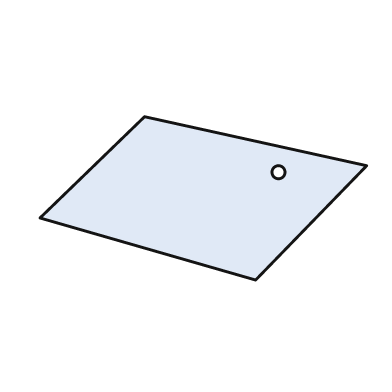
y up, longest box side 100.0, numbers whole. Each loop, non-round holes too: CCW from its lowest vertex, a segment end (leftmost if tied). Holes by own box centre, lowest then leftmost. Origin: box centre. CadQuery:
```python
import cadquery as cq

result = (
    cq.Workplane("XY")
    .moveTo(16.0, -25.0)
    .lineTo(50.0, 10.0)
    .lineTo(-18.0, 25.0)
    .lineTo(-50.0, -6.0)
    .close()
    .moveTo(23.0, 8.0)
    .circle(2.0)
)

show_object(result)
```